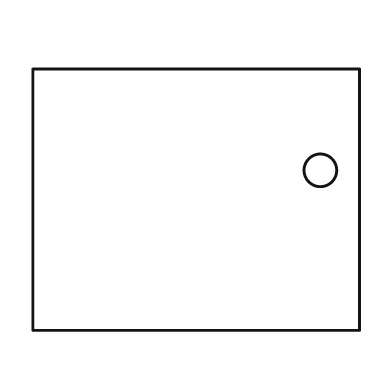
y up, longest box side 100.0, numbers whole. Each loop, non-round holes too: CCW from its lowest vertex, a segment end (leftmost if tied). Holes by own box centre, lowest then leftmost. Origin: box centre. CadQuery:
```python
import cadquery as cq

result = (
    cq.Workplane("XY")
    .moveTo(-50.0, -40.0)
    .lineTo(50.0, -40.0)
    .lineTo(50.0, 40.0)
    .lineTo(-50.0, 40.0)
    .close()
    .moveTo(38.0, 9.0)
    .circle(5.0)
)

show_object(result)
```